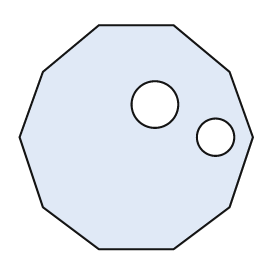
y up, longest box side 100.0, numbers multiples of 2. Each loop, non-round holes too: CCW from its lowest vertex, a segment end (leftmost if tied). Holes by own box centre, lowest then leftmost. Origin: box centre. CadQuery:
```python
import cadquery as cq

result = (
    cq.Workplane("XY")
    .moveTo(-16.0, -48.0)
    .lineTo(16.0, -48.0)
    .lineTo(40.0, -30.0)
    .lineTo(50.0, 0.0)
    .lineTo(40.0, 28.0)
    .lineTo(16.0, 48.0)
    .lineTo(-16.0, 48.0)
    .lineTo(-40.0, 28.0)
    .lineTo(-50.0, 0.0)
    .lineTo(-40.0, -30.0)
    .close()
    .moveTo(34.0, 0.0)
    .circle(8.0)
    .moveTo(8.0, 14.0)
    .circle(10.0)
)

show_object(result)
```